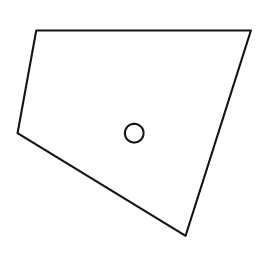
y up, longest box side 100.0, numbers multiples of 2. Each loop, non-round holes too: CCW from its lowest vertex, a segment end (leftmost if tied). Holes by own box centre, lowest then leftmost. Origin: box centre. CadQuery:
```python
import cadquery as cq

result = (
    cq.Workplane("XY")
    .moveTo(22.0, -44.0)
    .lineTo(50.0, 44.0)
    .lineTo(-42.0, 44.0)
    .lineTo(-50.0, 0.0)
    .close()
    .moveTo(0.0, 0.0)
    .circle(4.0)
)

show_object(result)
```